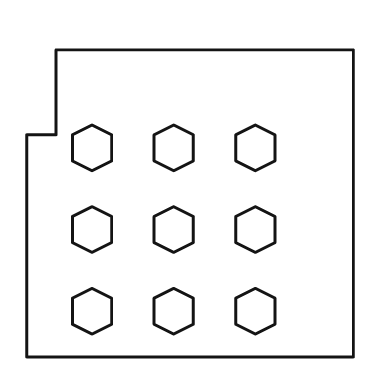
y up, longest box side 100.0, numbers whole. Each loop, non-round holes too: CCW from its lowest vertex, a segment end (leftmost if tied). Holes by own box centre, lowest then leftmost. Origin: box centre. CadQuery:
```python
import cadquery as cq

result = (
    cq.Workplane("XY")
    .moveTo(-50.0, -47.0)
    .lineTo(50.0, -47.0)
    .lineTo(50.0, 47.0)
    .lineTo(-41.0, 47.0)
    .lineTo(-41.0, 21.0)
    .lineTo(-50.0, 21.0)
    .close()
    .moveTo(-30.0, -40.0)
    .lineTo(-24.0, -37.0)
    .lineTo(-24.0, -29.0)
    .lineTo(-30.0, -26.0)
    .lineTo(-36.0, -29.0)
    .lineTo(-36.0, -37.0)
    .close()
    .moveTo(-5.0, -40.0)
    .lineTo(1.0, -37.0)
    .lineTo(1.0, -29.0)
    .lineTo(-5.0, -26.0)
    .lineTo(-11.0, -29.0)
    .lineTo(-11.0, -37.0)
    .close()
    .moveTo(20.0, -40.0)
    .lineTo(26.0, -37.0)
    .lineTo(26.0, -29.0)
    .lineTo(20.0, -26.0)
    .lineTo(14.0, -29.0)
    .lineTo(14.0, -37.0)
    .close()
    .moveTo(-30.0, -15.0)
    .lineTo(-24.0, -12.0)
    .lineTo(-24.0, -4.0)
    .lineTo(-30.0, -1.0)
    .lineTo(-36.0, -4.0)
    .lineTo(-36.0, -12.0)
    .close()
    .moveTo(-5.0, -15.0)
    .lineTo(1.0, -12.0)
    .lineTo(1.0, -4.0)
    .lineTo(-5.0, -1.0)
    .lineTo(-11.0, -4.0)
    .lineTo(-11.0, -12.0)
    .close()
    .moveTo(20.0, -15.0)
    .lineTo(26.0, -12.0)
    .lineTo(26.0, -4.0)
    .lineTo(20.0, -1.0)
    .lineTo(14.0, -4.0)
    .lineTo(14.0, -12.0)
    .close()
    .moveTo(-30.0, 10.0)
    .lineTo(-24.0, 13.0)
    .lineTo(-24.0, 21.0)
    .lineTo(-30.0, 24.0)
    .lineTo(-36.0, 21.0)
    .lineTo(-36.0, 13.0)
    .close()
    .moveTo(-5.0, 10.0)
    .lineTo(1.0, 13.0)
    .lineTo(1.0, 21.0)
    .lineTo(-5.0, 24.0)
    .lineTo(-11.0, 21.0)
    .lineTo(-11.0, 13.0)
    .close()
    .moveTo(20.0, 10.0)
    .lineTo(26.0, 13.0)
    .lineTo(26.0, 21.0)
    .lineTo(20.0, 24.0)
    .lineTo(14.0, 21.0)
    .lineTo(14.0, 13.0)
    .close()
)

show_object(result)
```